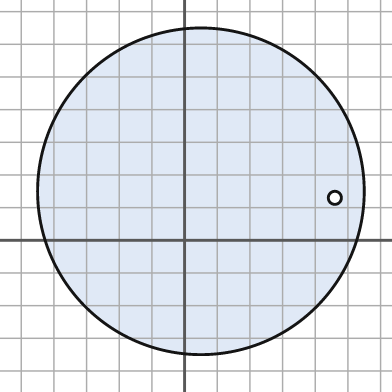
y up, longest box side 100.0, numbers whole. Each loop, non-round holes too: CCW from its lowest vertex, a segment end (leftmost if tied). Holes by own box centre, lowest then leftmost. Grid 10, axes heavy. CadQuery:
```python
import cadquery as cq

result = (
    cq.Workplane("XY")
    .moveTo(5.0, 15.0)
    .circle(50.0)
    .moveTo(46.0, 13.0)
    .circle(2.0)
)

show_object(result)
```